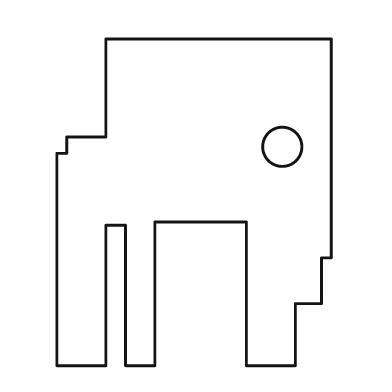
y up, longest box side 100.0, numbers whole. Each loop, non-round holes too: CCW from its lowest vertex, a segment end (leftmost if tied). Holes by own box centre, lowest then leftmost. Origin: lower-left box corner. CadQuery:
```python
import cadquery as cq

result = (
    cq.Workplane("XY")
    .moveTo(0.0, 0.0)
    .lineTo(15.0, 0.0)
    .lineTo(15.0, 43.0)
    .lineTo(21.0, 43.0)
    .lineTo(21.0, 0.0)
    .lineTo(30.0, 0.0)
    .lineTo(30.0, 44.0)
    .lineTo(58.0, 44.0)
    .lineTo(58.0, 0.0)
    .lineTo(73.0, 0.0)
    .lineTo(73.0, 19.0)
    .lineTo(81.0, 19.0)
    .lineTo(81.0, 33.0)
    .lineTo(84.0, 33.0)
    .lineTo(84.0, 100.0)
    .lineTo(15.0, 100.0)
    .lineTo(15.0, 70.0)
    .lineTo(3.0, 70.0)
    .lineTo(3.0, 65.0)
    .lineTo(0.0, 65.0)
    .close()
    .moveTo(69.0, 67.0)
    .circle(6.0)
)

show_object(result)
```